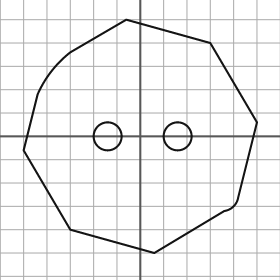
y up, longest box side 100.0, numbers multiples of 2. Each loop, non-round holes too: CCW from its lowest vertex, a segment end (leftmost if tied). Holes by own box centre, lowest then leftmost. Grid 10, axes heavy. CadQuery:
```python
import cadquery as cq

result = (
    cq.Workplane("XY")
    .moveTo(6.0, -50.0)
    .lineTo(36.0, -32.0)
    .threePointArc((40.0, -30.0), (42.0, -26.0))
    .lineTo(50.0, 6.0)
    .lineTo(30.0, 40.0)
    .lineTo(-6.0, 50.0)
    .lineTo(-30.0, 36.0)
    .threePointArc((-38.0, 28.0), (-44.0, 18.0))
    .lineTo(-50.0, -6.0)
    .lineTo(-30.0, -40.0)
    .close()
    .moveTo(-14.0, 0.0)
    .circle(6.0)
    .moveTo(16.0, 0.0)
    .circle(6.0)
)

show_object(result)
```